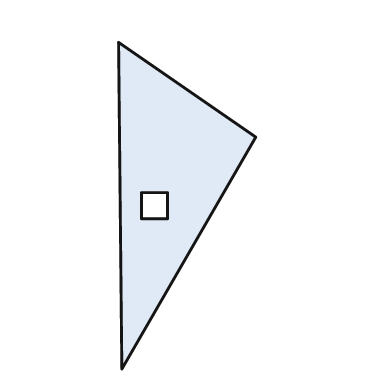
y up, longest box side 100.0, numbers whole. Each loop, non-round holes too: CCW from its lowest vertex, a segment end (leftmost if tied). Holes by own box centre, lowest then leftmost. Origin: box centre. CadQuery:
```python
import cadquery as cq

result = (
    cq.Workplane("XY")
    .moveTo(-20.0, -50.0)
    .lineTo(21.0, 21.0)
    .lineTo(-21.0, 50.0)
    .close()
    .moveTo(-14.0, -4.0)
    .lineTo(-6.0, -4.0)
    .lineTo(-6.0, 4.0)
    .lineTo(-14.0, 4.0)
    .close()
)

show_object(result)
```